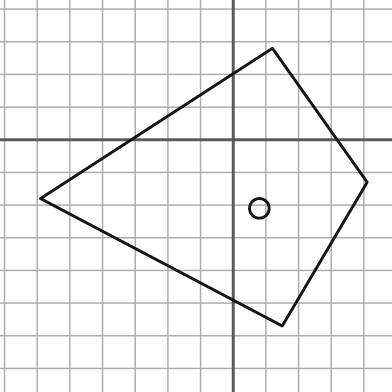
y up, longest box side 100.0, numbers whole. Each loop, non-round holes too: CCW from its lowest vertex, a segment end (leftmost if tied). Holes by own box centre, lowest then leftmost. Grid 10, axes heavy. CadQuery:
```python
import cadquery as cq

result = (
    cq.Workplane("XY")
    .moveTo(15.0, -57.0)
    .lineTo(41.0, -13.0)
    .lineTo(12.0, 28.0)
    .lineTo(-59.0, -18.0)
    .close()
    .moveTo(8.0, -21.0)
    .circle(3.0)
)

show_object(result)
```